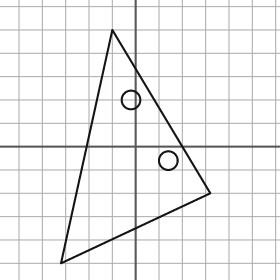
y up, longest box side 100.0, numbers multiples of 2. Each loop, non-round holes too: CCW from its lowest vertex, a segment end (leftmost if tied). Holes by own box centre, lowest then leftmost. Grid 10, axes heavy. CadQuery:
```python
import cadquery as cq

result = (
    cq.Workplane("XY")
    .moveTo(-32.0, -50.0)
    .lineTo(32.0, -20.0)
    .lineTo(-10.0, 50.0)
    .close()
    .moveTo(14.0, -6.0)
    .circle(4.0)
    .moveTo(-2.0, 20.0)
    .circle(4.0)
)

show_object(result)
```